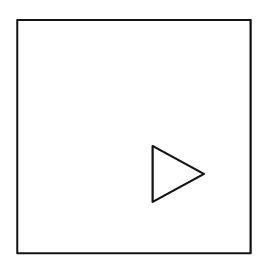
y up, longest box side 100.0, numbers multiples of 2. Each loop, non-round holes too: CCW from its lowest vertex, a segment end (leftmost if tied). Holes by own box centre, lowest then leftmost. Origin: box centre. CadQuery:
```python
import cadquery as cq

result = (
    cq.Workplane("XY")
    .moveTo(-50.0, -50.0)
    .lineTo(50.0, -50.0)
    .lineTo(50.0, 50.0)
    .lineTo(-50.0, 50.0)
    .close()
    .moveTo(8.0, -28.0)
    .lineTo(30.0, -16.0)
    .lineTo(8.0, -4.0)
    .close()
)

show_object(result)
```